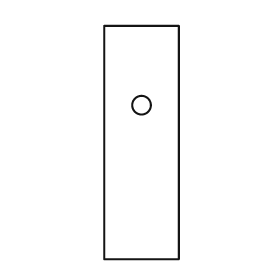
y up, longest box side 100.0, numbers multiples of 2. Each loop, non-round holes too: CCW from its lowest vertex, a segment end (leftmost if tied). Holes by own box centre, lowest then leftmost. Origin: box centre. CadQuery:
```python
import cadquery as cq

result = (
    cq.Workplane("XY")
    .moveTo(-16.0, -50.0)
    .lineTo(16.0, -50.0)
    .lineTo(16.0, 50.0)
    .lineTo(-16.0, 50.0)
    .close()
    .moveTo(0.0, 16.0)
    .circle(4.0)
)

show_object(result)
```